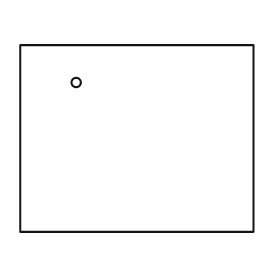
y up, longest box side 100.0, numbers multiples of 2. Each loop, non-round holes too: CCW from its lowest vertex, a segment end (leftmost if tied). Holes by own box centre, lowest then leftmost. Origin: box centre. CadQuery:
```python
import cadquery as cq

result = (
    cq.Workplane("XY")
    .moveTo(-50.0, -40.0)
    .lineTo(50.0, -40.0)
    .lineTo(50.0, 40.0)
    .lineTo(-50.0, 40.0)
    .close()
    .moveTo(-26.0, 24.0)
    .circle(2.0)
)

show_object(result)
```